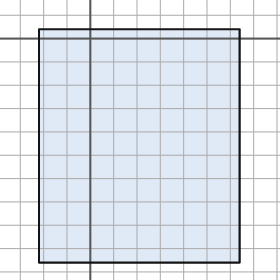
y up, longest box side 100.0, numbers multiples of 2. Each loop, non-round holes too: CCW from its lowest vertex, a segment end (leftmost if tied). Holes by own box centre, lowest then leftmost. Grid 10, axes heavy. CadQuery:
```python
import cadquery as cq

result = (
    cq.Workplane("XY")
    .moveTo(-22.0, -96.0)
    .lineTo(64.0, -96.0)
    .lineTo(64.0, 4.0)
    .lineTo(-22.0, 4.0)
    .close()
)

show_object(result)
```